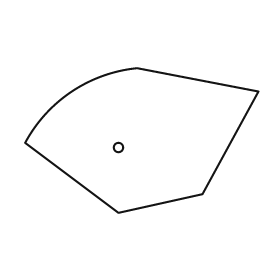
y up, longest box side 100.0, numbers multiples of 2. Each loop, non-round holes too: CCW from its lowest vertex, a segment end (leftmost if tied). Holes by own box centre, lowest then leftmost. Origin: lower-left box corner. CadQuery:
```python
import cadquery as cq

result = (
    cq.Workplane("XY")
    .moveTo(40.0, 0.0)
    .lineTo(76.0, 8.0)
    .lineTo(100.0, 52.0)
    .lineTo(48.0, 62.0)
    .threePointArc((20.0, 52.0), (0.0, 30.0))
    .close()
    .moveTo(40.0, 28.0)
    .circle(2.0)
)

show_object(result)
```